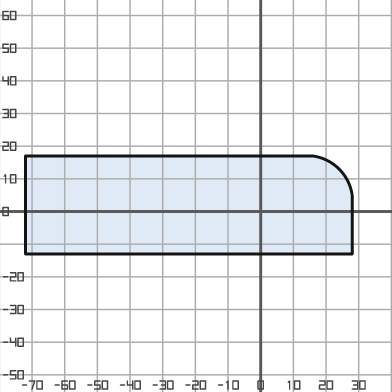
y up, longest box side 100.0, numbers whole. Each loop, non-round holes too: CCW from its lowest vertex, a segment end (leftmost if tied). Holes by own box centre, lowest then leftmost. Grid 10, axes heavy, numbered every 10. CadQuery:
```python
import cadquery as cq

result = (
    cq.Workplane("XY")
    .moveTo(-72.0, -13.0)
    .lineTo(28.0, -13.0)
    .lineTo(28.0, 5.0)
    .threePointArc((24.0, 13.0), (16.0, 17.0))
    .lineTo(-72.0, 17.0)
    .close()
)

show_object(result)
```